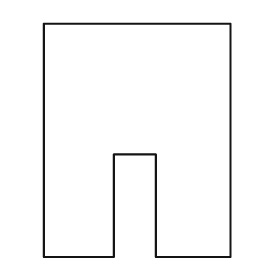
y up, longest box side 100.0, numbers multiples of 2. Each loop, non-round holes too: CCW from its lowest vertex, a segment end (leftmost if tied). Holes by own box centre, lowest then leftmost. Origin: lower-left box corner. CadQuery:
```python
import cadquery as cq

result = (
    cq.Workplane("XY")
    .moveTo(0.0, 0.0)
    .lineTo(30.0, 0.0)
    .lineTo(30.0, 44.0)
    .lineTo(48.0, 44.0)
    .lineTo(48.0, 0.0)
    .lineTo(80.0, 0.0)
    .lineTo(80.0, 100.0)
    .lineTo(0.0, 100.0)
    .close()
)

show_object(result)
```